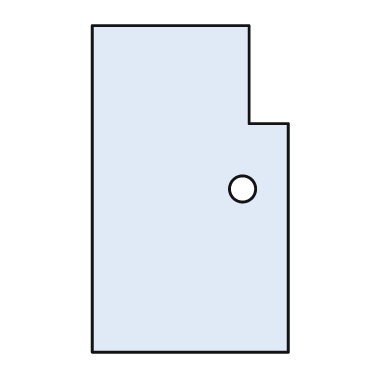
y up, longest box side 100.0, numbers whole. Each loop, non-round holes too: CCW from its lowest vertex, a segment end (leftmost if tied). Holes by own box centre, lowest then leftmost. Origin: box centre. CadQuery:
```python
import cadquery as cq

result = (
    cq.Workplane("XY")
    .moveTo(-30.0, -50.0)
    .lineTo(30.0, -50.0)
    .lineTo(30.0, 20.0)
    .lineTo(18.0, 20.0)
    .lineTo(18.0, 50.0)
    .lineTo(-30.0, 50.0)
    .close()
    .moveTo(16.0, 0.0)
    .circle(4.0)
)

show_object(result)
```